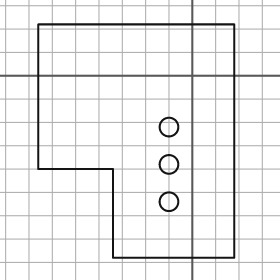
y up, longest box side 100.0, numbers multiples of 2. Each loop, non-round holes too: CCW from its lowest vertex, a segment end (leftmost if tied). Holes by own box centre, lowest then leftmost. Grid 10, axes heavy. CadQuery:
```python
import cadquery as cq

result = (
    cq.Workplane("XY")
    .moveTo(-34.0, -78.0)
    .lineTo(18.0, -78.0)
    .lineTo(18.0, 22.0)
    .lineTo(-66.0, 22.0)
    .lineTo(-66.0, -40.0)
    .lineTo(-34.0, -40.0)
    .close()
    .moveTo(-10.0, -54.0)
    .circle(4.0)
    .moveTo(-10.0, -38.0)
    .circle(4.0)
    .moveTo(-10.0, -22.0)
    .circle(4.0)
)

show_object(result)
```